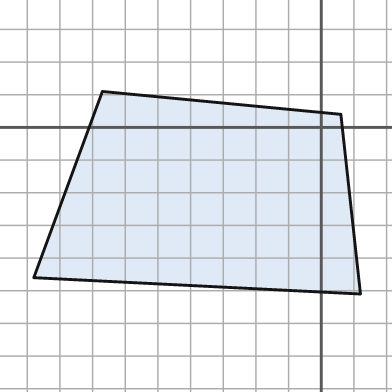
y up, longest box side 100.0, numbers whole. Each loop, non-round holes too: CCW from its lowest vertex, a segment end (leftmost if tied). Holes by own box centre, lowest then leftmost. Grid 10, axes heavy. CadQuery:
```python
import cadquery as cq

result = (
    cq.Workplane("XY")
    .moveTo(12.0, -51.0)
    .lineTo(6.0, 4.0)
    .lineTo(-67.0, 11.0)
    .lineTo(-88.0, -46.0)
    .close()
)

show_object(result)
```